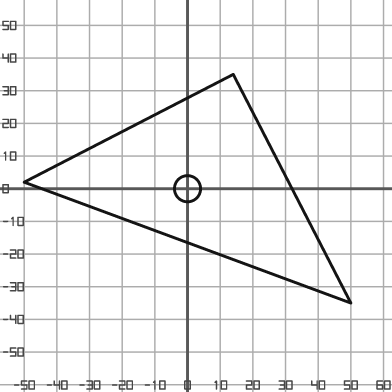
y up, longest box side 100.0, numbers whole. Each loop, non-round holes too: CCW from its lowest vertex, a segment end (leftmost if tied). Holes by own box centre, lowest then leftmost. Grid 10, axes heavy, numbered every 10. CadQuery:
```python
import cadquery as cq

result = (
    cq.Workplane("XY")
    .moveTo(50.0, -35.0)
    .lineTo(14.0, 35.0)
    .lineTo(-50.0, 2.0)
    .close()
    .moveTo(0.0, 0.0)
    .circle(4.0)
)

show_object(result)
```